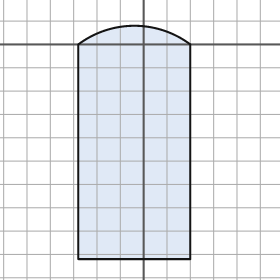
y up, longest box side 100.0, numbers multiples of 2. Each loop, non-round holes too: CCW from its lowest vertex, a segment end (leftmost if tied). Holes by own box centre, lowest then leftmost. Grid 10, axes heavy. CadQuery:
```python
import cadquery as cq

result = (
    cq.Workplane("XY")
    .moveTo(-28.0, -92.0)
    .lineTo(20.0, -92.0)
    .lineTo(20.0, 0.0)
    .threePointArc((-4.0, 8.0), (-28.0, 0.0))
    .close()
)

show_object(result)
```